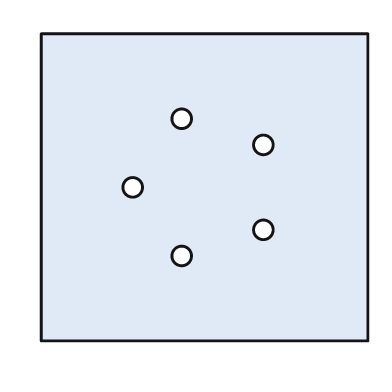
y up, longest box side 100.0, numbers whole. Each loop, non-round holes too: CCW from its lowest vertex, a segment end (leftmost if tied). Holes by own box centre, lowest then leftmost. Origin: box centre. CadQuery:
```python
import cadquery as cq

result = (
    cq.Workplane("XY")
    .moveTo(-50.0, -47.0)
    .lineTo(50.0, -47.0)
    .lineTo(50.0, 47.0)
    .lineTo(-50.0, 47.0)
    .close()
    .moveTo(-7.0, -21.0)
    .circle(3.0)
    .moveTo(18.0, -13.0)
    .circle(3.0)
    .moveTo(-22.0, 0.0)
    .circle(3.0)
    .moveTo(18.0, 13.0)
    .circle(3.0)
    .moveTo(-7.0, 21.0)
    .circle(3.0)
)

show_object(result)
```